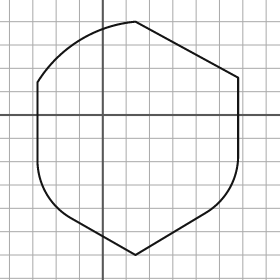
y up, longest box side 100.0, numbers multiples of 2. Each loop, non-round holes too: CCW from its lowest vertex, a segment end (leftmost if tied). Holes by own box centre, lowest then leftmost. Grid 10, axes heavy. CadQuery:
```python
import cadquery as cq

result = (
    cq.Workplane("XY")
    .moveTo(14.0, -60.0)
    .lineTo(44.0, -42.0)
    .threePointArc((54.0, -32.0), (58.0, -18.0))
    .lineTo(58.0, 16.0)
    .lineTo(14.0, 40.0)
    .threePointArc((-10.0, 32.0), (-28.0, 14.0))
    .lineTo(-28.0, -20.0)
    .threePointArc((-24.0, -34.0), (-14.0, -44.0))
    .close()
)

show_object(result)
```